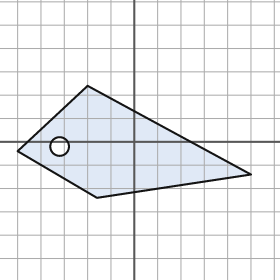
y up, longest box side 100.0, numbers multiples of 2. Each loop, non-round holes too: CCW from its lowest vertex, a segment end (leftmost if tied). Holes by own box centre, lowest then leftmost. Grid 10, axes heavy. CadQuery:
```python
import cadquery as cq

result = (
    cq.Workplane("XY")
    .moveTo(-16.0, -24.0)
    .lineTo(50.0, -14.0)
    .lineTo(-20.0, 24.0)
    .lineTo(-50.0, -4.0)
    .close()
    .moveTo(-32.0, -2.0)
    .circle(4.0)
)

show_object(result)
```